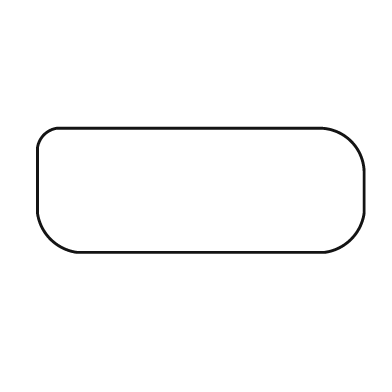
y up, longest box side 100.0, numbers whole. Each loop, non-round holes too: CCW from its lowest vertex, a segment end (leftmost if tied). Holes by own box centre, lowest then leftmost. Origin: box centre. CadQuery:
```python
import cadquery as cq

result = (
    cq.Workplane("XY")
    .moveTo(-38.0, -19.0)
    .lineTo(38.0, -19.0)
    .threePointArc((46.0, -15.0), (50.0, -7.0))
    .lineTo(50.0, 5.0)
    .threePointArc((46.0, 15.0), (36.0, 19.0))
    .lineTo(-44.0, 19.0)
    .threePointArc((-48.0, 17.0), (-50.0, 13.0))
    .lineTo(-50.0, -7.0)
    .threePointArc((-46.0, -15.0), (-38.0, -19.0))
    .close()
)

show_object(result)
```